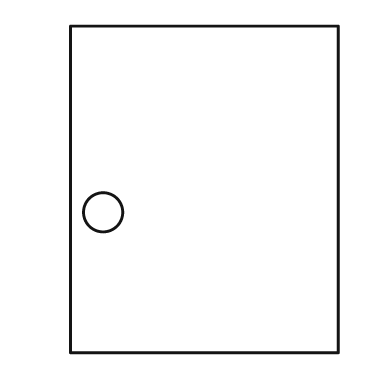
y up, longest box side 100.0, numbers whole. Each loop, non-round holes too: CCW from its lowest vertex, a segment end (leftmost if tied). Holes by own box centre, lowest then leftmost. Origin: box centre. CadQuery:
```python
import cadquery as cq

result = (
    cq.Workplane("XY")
    .moveTo(-41.0, -50.0)
    .lineTo(41.0, -50.0)
    .lineTo(41.0, 50.0)
    .lineTo(-41.0, 50.0)
    .close()
    .moveTo(-31.0, -7.0)
    .circle(6.0)
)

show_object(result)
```